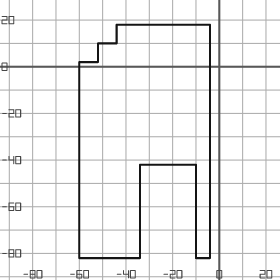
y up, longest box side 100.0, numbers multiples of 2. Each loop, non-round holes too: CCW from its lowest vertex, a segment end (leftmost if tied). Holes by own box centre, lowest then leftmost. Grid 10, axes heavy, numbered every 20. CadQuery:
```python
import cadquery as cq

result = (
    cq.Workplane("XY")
    .moveTo(-60.0, -82.0)
    .lineTo(-34.0, -82.0)
    .lineTo(-34.0, -42.0)
    .lineTo(-10.0, -42.0)
    .lineTo(-10.0, -82.0)
    .lineTo(-4.0, -82.0)
    .lineTo(-4.0, 18.0)
    .lineTo(-44.0, 18.0)
    .lineTo(-44.0, 10.0)
    .lineTo(-52.0, 10.0)
    .lineTo(-52.0, 2.0)
    .lineTo(-60.0, 2.0)
    .close()
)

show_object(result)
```